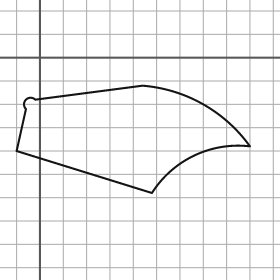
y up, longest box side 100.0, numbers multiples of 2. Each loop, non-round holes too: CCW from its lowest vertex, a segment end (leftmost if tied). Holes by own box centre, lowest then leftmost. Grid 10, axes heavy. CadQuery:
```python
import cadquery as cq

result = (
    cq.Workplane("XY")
    .moveTo(48.0, -58.0)
    .threePointArc((66.0, -42.0), (90.0, -38.0))
    .threePointArc((70.0, -20.0), (44.0, -12.0))
    .lineTo(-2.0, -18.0)
    .threePointArc((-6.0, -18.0), (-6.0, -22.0))
    .lineTo(-10.0, -40.0)
    .close()
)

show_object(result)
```